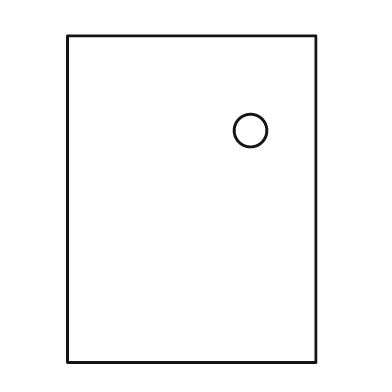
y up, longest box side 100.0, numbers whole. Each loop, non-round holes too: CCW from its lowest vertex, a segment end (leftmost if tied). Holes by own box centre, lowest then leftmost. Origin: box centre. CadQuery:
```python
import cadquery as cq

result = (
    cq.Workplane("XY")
    .moveTo(-38.0, -50.0)
    .lineTo(38.0, -50.0)
    .lineTo(38.0, 50.0)
    .lineTo(-38.0, 50.0)
    .close()
    .moveTo(18.0, 21.0)
    .circle(5.0)
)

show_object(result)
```